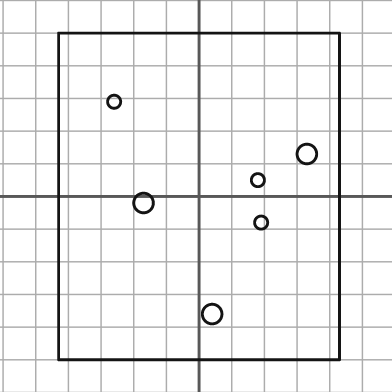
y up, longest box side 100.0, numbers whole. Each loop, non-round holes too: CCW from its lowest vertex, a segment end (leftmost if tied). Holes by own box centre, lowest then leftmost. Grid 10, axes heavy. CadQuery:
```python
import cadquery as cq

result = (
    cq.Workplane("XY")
    .moveTo(-43.0, -50.0)
    .lineTo(43.0, -50.0)
    .lineTo(43.0, 50.0)
    .lineTo(-43.0, 50.0)
    .close()
    .moveTo(4.0, -36.0)
    .circle(3.0)
    .moveTo(19.0, -8.0)
    .circle(2.0)
    .moveTo(-17.0, -2.0)
    .circle(3.0)
    .moveTo(18.0, 5.0)
    .circle(2.0)
    .moveTo(33.0, 13.0)
    .circle(3.0)
    .moveTo(-26.0, 29.0)
    .circle(2.0)
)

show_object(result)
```